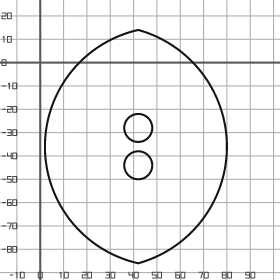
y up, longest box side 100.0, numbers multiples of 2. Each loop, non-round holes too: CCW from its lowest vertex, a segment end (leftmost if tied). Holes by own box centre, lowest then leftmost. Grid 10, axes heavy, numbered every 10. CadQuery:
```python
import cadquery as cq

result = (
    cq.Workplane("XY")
    .moveTo(42.0, -86.0)
    .threePointArc((80.0, -36.0), (42.0, 14.0))
    .threePointArc((2.0, -36.0), (42.0, -86.0))
    .close()
    .moveTo(42.0, -44.0)
    .circle(6.0)
    .moveTo(42.0, -28.0)
    .circle(6.0)
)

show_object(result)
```